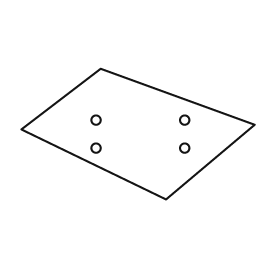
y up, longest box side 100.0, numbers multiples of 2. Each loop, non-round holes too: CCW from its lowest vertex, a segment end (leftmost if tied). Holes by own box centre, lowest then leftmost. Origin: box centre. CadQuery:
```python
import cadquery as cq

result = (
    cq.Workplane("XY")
    .moveTo(12.0, -28.0)
    .lineTo(50.0, 4.0)
    .lineTo(-16.0, 28.0)
    .lineTo(-50.0, 2.0)
    .close()
    .moveTo(-18.0, -6.0)
    .circle(2.0)
    .moveTo(20.0, -6.0)
    .circle(2.0)
    .moveTo(-18.0, 6.0)
    .circle(2.0)
    .moveTo(20.0, 6.0)
    .circle(2.0)
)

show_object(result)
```